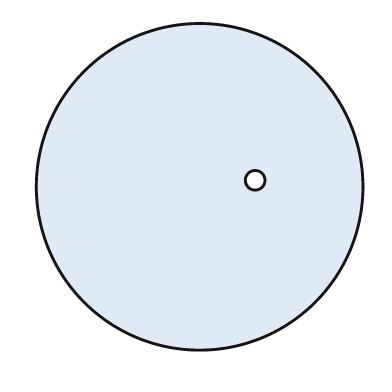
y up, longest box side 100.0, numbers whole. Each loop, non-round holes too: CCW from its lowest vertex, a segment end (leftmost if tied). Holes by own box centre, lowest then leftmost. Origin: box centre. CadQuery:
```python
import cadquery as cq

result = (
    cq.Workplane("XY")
    .moveTo(0.0, 0.0)
    .circle(50.0)
    .moveTo(17.0, 2.0)
    .circle(3.0)
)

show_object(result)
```